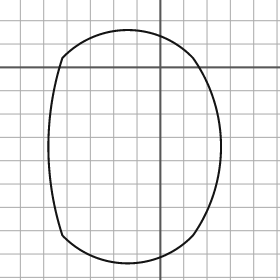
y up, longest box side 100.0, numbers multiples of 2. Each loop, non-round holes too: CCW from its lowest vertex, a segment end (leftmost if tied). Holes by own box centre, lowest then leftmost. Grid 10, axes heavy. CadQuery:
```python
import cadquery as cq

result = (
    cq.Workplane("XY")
    .moveTo(-42.0, -72.0)
    .threePointArc((-14.0, -84.0), (14.0, -72.0))
    .threePointArc((26.0, -34.0), (14.0, 4.0))
    .threePointArc((-14.0, 16.0), (-42.0, 4.0))
    .threePointArc((-48.0, -34.0), (-42.0, -72.0))
    .close()
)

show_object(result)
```